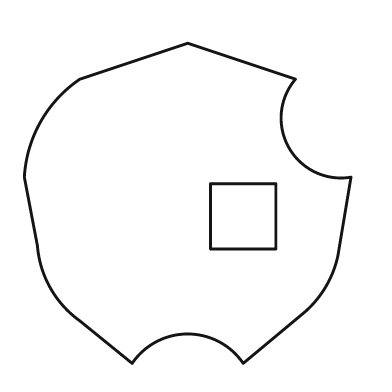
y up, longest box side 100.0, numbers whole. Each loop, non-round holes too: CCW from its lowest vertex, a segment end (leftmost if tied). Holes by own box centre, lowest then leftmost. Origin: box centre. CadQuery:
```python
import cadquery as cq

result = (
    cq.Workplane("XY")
    .moveTo(-17.0, -49.0)
    .threePointArc((0.0, -40.0), (17.0, -49.0))
    .lineTo(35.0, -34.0)
    .threePointArc((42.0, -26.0), (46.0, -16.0))
    .lineTo(50.0, 8.0)
    .threePointArc((31.0, 17.0), (33.0, 38.0))
    .lineTo(0.0, 49.0)
    .lineTo(-33.0, 38.0)
    .threePointArc((-45.0, 25.0), (-50.0, 8.0))
    .lineTo(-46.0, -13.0)
    .threePointArc((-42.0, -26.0), (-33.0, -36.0))
    .close()
    .moveTo(7.0, -14.0)
    .lineTo(27.0, -14.0)
    .lineTo(27.0, 6.0)
    .lineTo(7.0, 6.0)
    .close()
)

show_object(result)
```